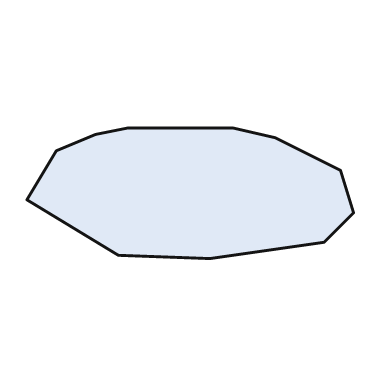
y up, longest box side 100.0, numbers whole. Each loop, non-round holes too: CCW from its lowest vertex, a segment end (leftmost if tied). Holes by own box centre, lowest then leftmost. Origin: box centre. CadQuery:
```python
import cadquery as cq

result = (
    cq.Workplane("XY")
    .moveTo(6.0, -20.0)
    .lineTo(41.0, -15.0)
    .lineTo(50.0, -6.0)
    .lineTo(46.0, 7.0)
    .lineTo(26.0, 17.0)
    .lineTo(13.0, 20.0)
    .lineTo(-19.0, 20.0)
    .lineTo(-29.0, 18.0)
    .lineTo(-41.0, 13.0)
    .lineTo(-50.0, -2.0)
    .lineTo(-22.0, -19.0)
    .close()
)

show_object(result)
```